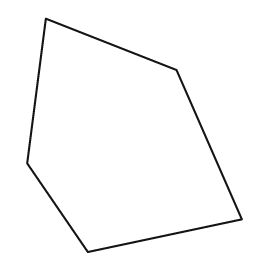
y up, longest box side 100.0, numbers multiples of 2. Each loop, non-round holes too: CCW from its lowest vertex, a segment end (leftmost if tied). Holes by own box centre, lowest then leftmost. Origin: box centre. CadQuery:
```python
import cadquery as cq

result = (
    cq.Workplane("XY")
    .moveTo(-20.0, -50.0)
    .lineTo(46.0, -36.0)
    .lineTo(18.0, 28.0)
    .lineTo(-38.0, 50.0)
    .lineTo(-46.0, -12.0)
    .close()
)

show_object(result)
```